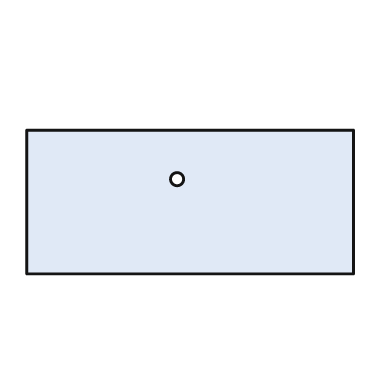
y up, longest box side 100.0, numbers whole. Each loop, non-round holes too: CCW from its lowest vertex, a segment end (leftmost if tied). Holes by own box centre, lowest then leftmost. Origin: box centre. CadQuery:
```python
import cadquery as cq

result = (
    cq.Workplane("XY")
    .moveTo(-50.0, -22.0)
    .lineTo(50.0, -22.0)
    .lineTo(50.0, 22.0)
    .lineTo(-50.0, 22.0)
    .close()
    .moveTo(-4.0, 7.0)
    .circle(2.0)
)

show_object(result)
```